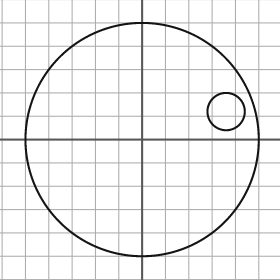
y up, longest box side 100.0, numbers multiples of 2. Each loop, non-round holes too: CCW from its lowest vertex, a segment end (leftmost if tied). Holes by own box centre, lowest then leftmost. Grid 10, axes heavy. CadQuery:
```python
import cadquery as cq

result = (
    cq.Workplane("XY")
    .moveTo(0.0, 0.0)
    .circle(50.0)
    .moveTo(36.0, 12.0)
    .circle(8.0)
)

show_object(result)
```